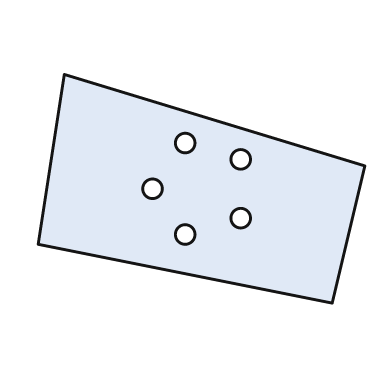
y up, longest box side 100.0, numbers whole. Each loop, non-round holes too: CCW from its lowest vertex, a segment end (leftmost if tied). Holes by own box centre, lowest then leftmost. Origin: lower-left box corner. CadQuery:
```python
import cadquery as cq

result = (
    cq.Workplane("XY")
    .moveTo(90.0, 0.0)
    .lineTo(100.0, 42.0)
    .lineTo(8.0, 70.0)
    .lineTo(0.0, 18.0)
    .close()
    .moveTo(45.0, 21.0)
    .circle(3.0)
    .moveTo(62.0, 26.0)
    .circle(3.0)
    .moveTo(35.0, 35.0)
    .circle(3.0)
    .moveTo(62.0, 44.0)
    .circle(3.0)
    .moveTo(45.0, 49.0)
    .circle(3.0)
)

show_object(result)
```